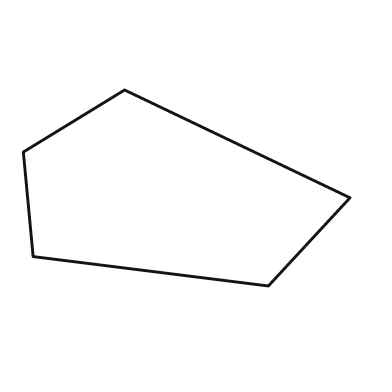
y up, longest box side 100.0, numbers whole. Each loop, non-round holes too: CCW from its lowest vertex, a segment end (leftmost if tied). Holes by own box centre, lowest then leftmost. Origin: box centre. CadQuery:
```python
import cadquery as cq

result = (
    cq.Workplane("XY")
    .moveTo(25.0, -30.0)
    .lineTo(50.0, -3.0)
    .lineTo(-19.0, 30.0)
    .lineTo(-50.0, 11.0)
    .lineTo(-47.0, -21.0)
    .close()
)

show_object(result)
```